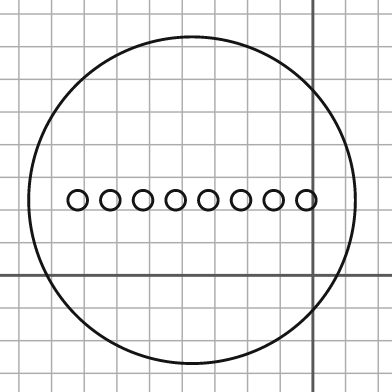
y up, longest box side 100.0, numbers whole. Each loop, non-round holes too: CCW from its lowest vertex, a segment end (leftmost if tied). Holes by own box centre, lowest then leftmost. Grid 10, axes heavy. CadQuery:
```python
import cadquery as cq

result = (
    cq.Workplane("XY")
    .moveTo(-37.0, 23.0)
    .circle(50.0)
    .moveTo(-72.0, 23.0)
    .circle(3.0)
    .moveTo(-62.0, 23.0)
    .circle(3.0)
    .moveTo(-52.0, 23.0)
    .circle(3.0)
    .moveTo(-42.0, 23.0)
    .circle(3.0)
    .moveTo(-32.0, 23.0)
    .circle(3.0)
    .moveTo(-22.0, 23.0)
    .circle(3.0)
    .moveTo(-12.0, 23.0)
    .circle(3.0)
    .moveTo(-2.0, 23.0)
    .circle(3.0)
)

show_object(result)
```